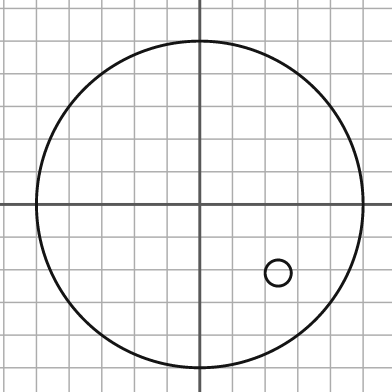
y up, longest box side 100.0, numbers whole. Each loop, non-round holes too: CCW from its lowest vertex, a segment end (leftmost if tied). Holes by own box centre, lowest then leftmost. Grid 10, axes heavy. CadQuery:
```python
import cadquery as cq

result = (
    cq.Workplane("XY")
    .moveTo(0.0, 0.0)
    .circle(50.0)
    .moveTo(24.0, -21.0)
    .circle(4.0)
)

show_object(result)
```